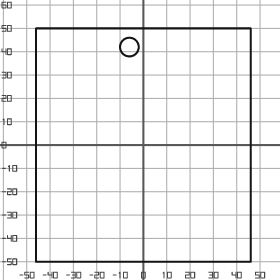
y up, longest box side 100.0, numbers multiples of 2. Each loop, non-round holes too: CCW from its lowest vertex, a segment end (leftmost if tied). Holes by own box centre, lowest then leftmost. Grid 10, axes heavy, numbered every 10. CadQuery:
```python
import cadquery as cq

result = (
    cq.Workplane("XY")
    .moveTo(-46.0, -50.0)
    .lineTo(46.0, -50.0)
    .lineTo(46.0, 50.0)
    .lineTo(-46.0, 50.0)
    .close()
    .moveTo(-6.0, 42.0)
    .circle(4.0)
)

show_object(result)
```